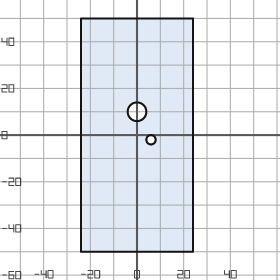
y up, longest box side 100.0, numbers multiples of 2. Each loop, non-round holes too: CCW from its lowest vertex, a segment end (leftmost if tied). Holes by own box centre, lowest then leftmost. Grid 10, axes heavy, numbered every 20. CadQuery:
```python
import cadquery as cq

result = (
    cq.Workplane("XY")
    .moveTo(-24.0, -50.0)
    .lineTo(24.0, -50.0)
    .lineTo(24.0, 50.0)
    .lineTo(-24.0, 50.0)
    .close()
    .moveTo(6.0, -2.0)
    .circle(2.0)
    .moveTo(0.0, 10.0)
    .circle(4.0)
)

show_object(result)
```